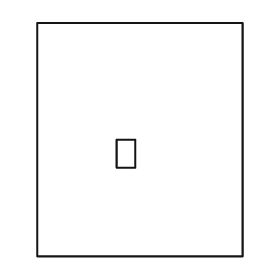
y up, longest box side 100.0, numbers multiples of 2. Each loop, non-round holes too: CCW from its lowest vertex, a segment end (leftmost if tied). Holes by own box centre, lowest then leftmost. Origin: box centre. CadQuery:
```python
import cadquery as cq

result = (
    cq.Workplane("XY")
    .moveTo(-44.0, -50.0)
    .lineTo(44.0, -50.0)
    .lineTo(44.0, 50.0)
    .lineTo(-44.0, 50.0)
    .close()
    .moveTo(-10.0, -12.0)
    .lineTo(-2.0, -12.0)
    .lineTo(-2.0, 0.0)
    .lineTo(-10.0, 0.0)
    .close()
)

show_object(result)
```